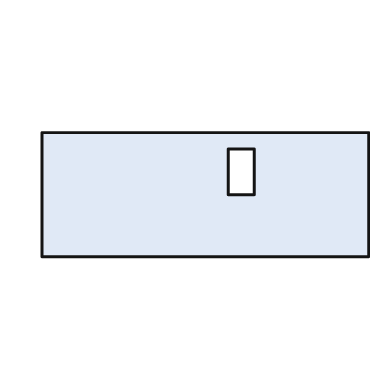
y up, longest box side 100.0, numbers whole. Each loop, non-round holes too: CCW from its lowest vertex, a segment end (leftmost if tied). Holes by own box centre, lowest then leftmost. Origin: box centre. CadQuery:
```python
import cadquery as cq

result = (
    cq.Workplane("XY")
    .moveTo(-50.0, -19.0)
    .lineTo(50.0, -19.0)
    .lineTo(50.0, 19.0)
    .lineTo(-50.0, 19.0)
    .close()
    .moveTo(7.0, 0.0)
    .lineTo(15.0, 0.0)
    .lineTo(15.0, 14.0)
    .lineTo(7.0, 14.0)
    .close()
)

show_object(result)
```